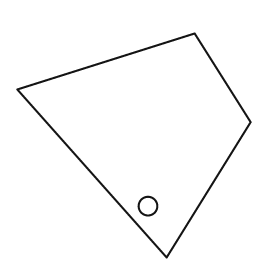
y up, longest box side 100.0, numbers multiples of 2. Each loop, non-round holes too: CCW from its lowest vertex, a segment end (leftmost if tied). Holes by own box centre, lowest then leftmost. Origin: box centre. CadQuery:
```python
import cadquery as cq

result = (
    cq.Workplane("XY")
    .moveTo(14.0, -48.0)
    .lineTo(50.0, 10.0)
    .lineTo(26.0, 48.0)
    .lineTo(-50.0, 24.0)
    .close()
    .moveTo(6.0, -26.0)
    .circle(4.0)
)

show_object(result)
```